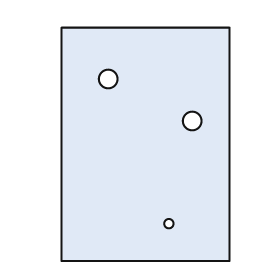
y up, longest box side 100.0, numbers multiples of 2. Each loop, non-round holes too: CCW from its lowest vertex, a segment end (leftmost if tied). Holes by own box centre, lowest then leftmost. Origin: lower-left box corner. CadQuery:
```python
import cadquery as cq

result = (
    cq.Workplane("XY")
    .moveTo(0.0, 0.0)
    .lineTo(72.0, 0.0)
    .lineTo(72.0, 100.0)
    .lineTo(0.0, 100.0)
    .close()
    .moveTo(46.0, 16.0)
    .circle(2.0)
    .moveTo(56.0, 60.0)
    .circle(4.0)
    .moveTo(20.0, 78.0)
    .circle(4.0)
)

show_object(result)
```